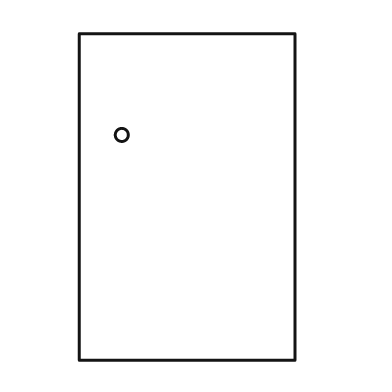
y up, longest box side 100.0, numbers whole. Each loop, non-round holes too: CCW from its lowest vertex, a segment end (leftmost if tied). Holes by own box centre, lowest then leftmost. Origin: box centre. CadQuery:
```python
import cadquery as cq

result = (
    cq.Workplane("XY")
    .moveTo(-33.0, -50.0)
    .lineTo(33.0, -50.0)
    .lineTo(33.0, 50.0)
    .lineTo(-33.0, 50.0)
    .close()
    .moveTo(-20.0, 19.0)
    .circle(2.0)
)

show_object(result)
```